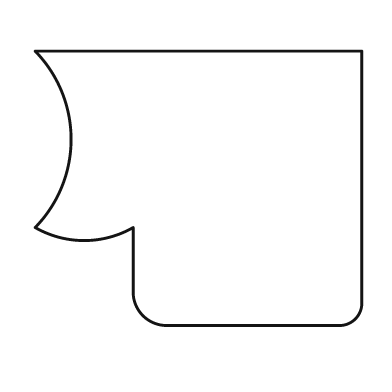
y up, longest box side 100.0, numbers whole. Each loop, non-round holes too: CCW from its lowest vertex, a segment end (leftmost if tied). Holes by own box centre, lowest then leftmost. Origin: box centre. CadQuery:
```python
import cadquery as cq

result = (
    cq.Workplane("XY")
    .moveTo(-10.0, -42.0)
    .lineTo(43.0, -42.0)
    .threePointArc((48.0, -40.0), (50.0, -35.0))
    .lineTo(50.0, 42.0)
    .lineTo(-50.0, 42.0)
    .threePointArc((-39.0, 15.0), (-50.0, -12.0))
    .threePointArc((-35.0, -16.0), (-20.0, -12.0))
    .lineTo(-20.0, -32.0)
    .threePointArc((-17.0, -39.0), (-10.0, -42.0))
    .close()
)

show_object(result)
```